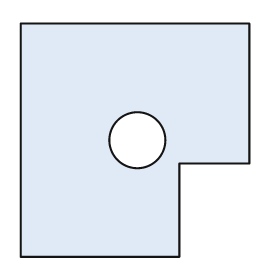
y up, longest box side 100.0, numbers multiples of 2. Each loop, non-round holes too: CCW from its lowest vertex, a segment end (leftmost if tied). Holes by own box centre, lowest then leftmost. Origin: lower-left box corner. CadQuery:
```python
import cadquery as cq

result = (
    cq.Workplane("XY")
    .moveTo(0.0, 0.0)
    .lineTo(68.0, 0.0)
    .lineTo(68.0, 40.0)
    .lineTo(98.0, 40.0)
    .lineTo(98.0, 100.0)
    .lineTo(0.0, 100.0)
    .close()
    .moveTo(50.0, 50.0)
    .circle(12.0)
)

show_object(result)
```